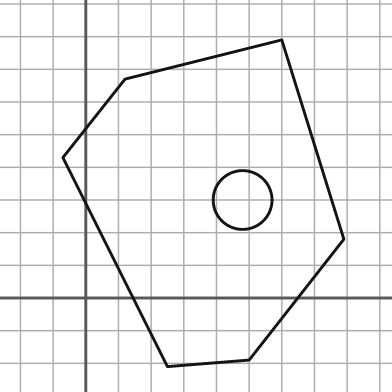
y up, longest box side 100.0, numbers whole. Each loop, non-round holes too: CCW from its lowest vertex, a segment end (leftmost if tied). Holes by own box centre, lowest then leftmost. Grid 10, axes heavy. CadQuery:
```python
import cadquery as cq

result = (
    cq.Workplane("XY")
    .moveTo(25.0, -21.0)
    .lineTo(50.0, -19.0)
    .lineTo(79.0, 18.0)
    .lineTo(60.0, 79.0)
    .lineTo(12.0, 67.0)
    .lineTo(-7.0, 43.0)
    .close()
    .moveTo(48.0, 30.0)
    .circle(9.0)
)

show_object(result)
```